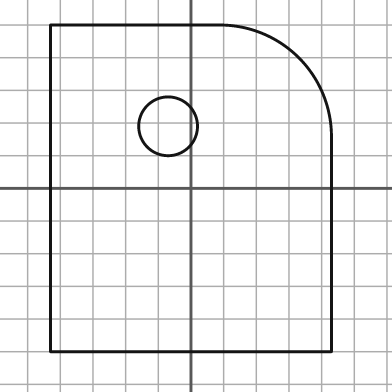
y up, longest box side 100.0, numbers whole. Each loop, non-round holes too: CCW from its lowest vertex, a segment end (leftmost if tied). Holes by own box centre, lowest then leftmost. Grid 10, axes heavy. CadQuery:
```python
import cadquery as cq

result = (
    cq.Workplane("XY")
    .moveTo(-43.0, -50.0)
    .lineTo(43.0, -50.0)
    .lineTo(43.0, 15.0)
    .threePointArc((33.0, 40.0), (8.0, 50.0))
    .lineTo(-43.0, 50.0)
    .close()
    .moveTo(-7.0, 19.0)
    .circle(9.0)
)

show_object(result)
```